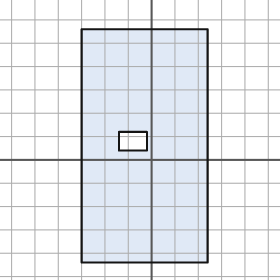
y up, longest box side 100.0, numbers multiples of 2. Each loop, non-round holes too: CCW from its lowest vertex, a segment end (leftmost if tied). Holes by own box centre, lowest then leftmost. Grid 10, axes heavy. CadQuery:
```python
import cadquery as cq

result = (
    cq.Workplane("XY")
    .moveTo(-30.0, -44.0)
    .lineTo(24.0, -44.0)
    .lineTo(24.0, 56.0)
    .lineTo(-30.0, 56.0)
    .close()
    .moveTo(-14.0, 4.0)
    .lineTo(-2.0, 4.0)
    .lineTo(-2.0, 12.0)
    .lineTo(-14.0, 12.0)
    .close()
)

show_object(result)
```